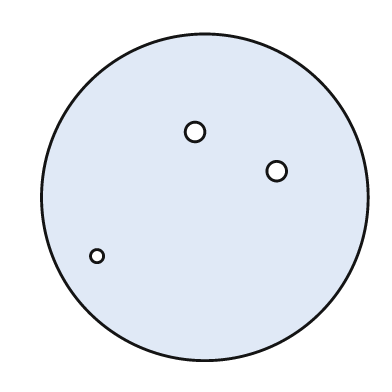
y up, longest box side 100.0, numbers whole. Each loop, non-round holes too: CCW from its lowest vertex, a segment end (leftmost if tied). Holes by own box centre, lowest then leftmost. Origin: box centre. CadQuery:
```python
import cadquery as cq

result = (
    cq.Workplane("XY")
    .moveTo(0.0, 0.0)
    .circle(50.0)
    .moveTo(-33.0, -18.0)
    .circle(2.0)
    .moveTo(22.0, 8.0)
    .circle(3.0)
    .moveTo(-3.0, 20.0)
    .circle(3.0)
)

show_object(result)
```